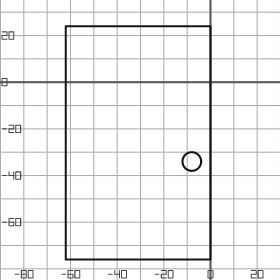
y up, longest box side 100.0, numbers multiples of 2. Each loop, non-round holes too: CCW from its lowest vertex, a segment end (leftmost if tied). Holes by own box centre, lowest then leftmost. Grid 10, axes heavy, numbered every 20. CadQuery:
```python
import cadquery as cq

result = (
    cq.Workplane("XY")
    .moveTo(-62.0, -76.0)
    .lineTo(0.0, -76.0)
    .lineTo(0.0, 24.0)
    .lineTo(-62.0, 24.0)
    .close()
    .moveTo(-8.0, -34.0)
    .circle(4.0)
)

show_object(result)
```